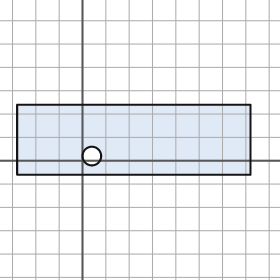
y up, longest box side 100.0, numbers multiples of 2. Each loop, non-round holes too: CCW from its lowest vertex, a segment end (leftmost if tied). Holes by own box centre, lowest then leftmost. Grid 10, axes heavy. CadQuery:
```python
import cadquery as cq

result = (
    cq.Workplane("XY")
    .moveTo(-28.0, -6.0)
    .lineTo(72.0, -6.0)
    .lineTo(72.0, 24.0)
    .lineTo(-28.0, 24.0)
    .close()
    .moveTo(4.0, 2.0)
    .circle(4.0)
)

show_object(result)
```